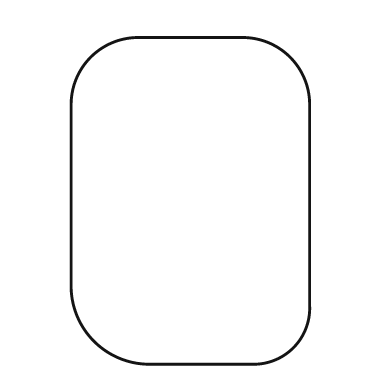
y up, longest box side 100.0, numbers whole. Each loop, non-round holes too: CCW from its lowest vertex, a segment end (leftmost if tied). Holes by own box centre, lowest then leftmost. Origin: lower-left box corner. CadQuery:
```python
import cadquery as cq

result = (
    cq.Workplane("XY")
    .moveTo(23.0, 0.0)
    .lineTo(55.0, 0.0)
    .threePointArc((68.0, 5.0), (73.0, 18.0))
    .lineTo(73.0, 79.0)
    .threePointArc((67.0, 94.0), (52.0, 100.0))
    .lineTo(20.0, 100.0)
    .threePointArc((6.0, 94.0), (0.0, 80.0))
    .lineTo(0.0, 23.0)
    .threePointArc((7.0, 7.0), (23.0, 0.0))
    .close()
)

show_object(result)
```